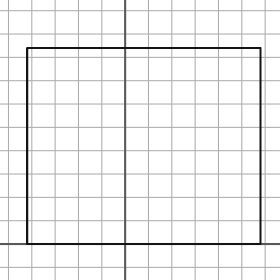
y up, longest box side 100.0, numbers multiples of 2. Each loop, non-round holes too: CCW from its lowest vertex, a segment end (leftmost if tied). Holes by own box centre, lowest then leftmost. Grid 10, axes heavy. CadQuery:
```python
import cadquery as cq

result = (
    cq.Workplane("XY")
    .moveTo(-42.0, 0.0)
    .lineTo(58.0, 0.0)
    .lineTo(58.0, 84.0)
    .lineTo(-42.0, 84.0)
    .close()
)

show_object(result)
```